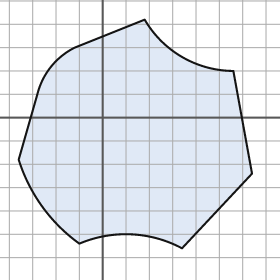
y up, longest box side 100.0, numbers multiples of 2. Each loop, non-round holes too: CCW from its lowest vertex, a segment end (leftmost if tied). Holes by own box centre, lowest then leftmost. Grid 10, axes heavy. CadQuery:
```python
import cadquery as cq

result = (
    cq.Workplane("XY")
    .moveTo(34.0, -56.0)
    .lineTo(64.0, -24.0)
    .lineTo(56.0, 20.0)
    .threePointArc((34.0, 26.0), (18.0, 42.0))
    .lineTo(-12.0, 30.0)
    .threePointArc((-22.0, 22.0), (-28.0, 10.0))
    .lineTo(-36.0, -18.0)
    .threePointArc((-26.0, -38.0), (-10.0, -54.0))
    .threePointArc((12.0, -50.0), (34.0, -56.0))
    .close()
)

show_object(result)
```